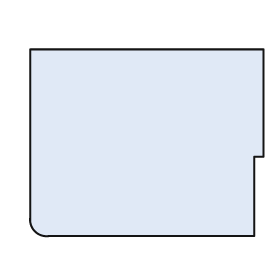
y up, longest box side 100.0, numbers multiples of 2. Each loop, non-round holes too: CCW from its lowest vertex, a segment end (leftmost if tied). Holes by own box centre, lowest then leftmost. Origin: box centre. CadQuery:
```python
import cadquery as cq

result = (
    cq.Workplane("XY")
    .moveTo(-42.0, -40.0)
    .lineTo(46.0, -40.0)
    .lineTo(46.0, -6.0)
    .lineTo(50.0, -6.0)
    .lineTo(50.0, 40.0)
    .lineTo(-50.0, 40.0)
    .lineTo(-50.0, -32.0)
    .threePointArc((-48.0, -38.0), (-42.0, -40.0))
    .close()
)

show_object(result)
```